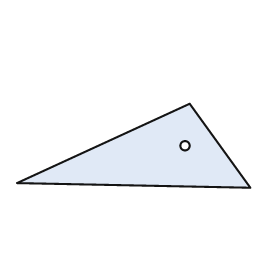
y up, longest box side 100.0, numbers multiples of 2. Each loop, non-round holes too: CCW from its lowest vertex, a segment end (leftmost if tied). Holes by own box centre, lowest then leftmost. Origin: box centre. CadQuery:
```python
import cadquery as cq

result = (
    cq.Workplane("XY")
    .moveTo(50.0, -18.0)
    .lineTo(24.0, 18.0)
    .lineTo(-50.0, -16.0)
    .close()
    .moveTo(22.0, 0.0)
    .circle(2.0)
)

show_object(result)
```